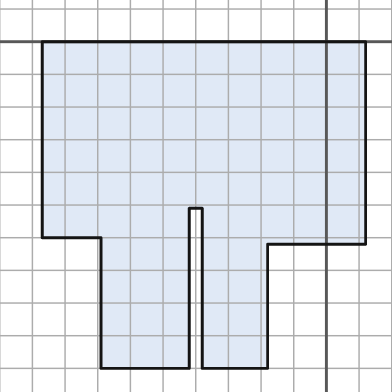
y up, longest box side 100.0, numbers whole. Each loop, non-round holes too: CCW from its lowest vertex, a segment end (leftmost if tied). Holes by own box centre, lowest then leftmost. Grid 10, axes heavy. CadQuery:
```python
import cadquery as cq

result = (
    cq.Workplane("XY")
    .moveTo(-69.0, -100.0)
    .lineTo(-42.0, -100.0)
    .lineTo(-42.0, -51.0)
    .lineTo(-38.0, -51.0)
    .lineTo(-38.0, -100.0)
    .lineTo(-18.0, -100.0)
    .lineTo(-18.0, -62.0)
    .lineTo(12.0, -62.0)
    .lineTo(12.0, 0.0)
    .lineTo(-87.0, 0.0)
    .lineTo(-87.0, -60.0)
    .lineTo(-69.0, -60.0)
    .close()
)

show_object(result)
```